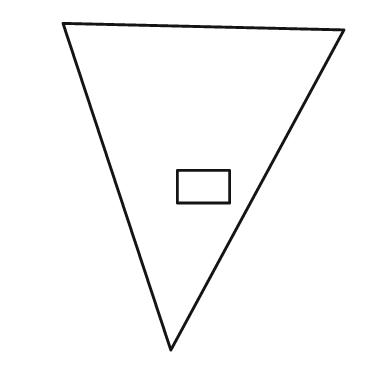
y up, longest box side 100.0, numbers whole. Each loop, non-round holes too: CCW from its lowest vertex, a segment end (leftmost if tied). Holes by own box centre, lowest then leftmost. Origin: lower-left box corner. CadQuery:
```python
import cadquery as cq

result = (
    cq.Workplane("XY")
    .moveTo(33.0, 0.0)
    .lineTo(86.0, 98.0)
    .lineTo(0.0, 100.0)
    .close()
    .moveTo(35.0, 45.0)
    .lineTo(51.0, 45.0)
    .lineTo(51.0, 55.0)
    .lineTo(35.0, 55.0)
    .close()
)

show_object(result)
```